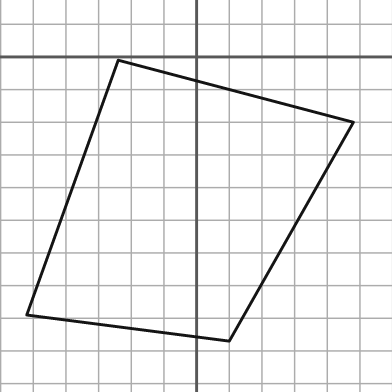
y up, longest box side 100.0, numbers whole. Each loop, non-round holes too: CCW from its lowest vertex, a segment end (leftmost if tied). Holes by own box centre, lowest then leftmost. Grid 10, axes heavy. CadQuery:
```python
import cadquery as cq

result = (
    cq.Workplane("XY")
    .moveTo(10.0, -87.0)
    .lineTo(48.0, -20.0)
    .lineTo(-24.0, -1.0)
    .lineTo(-52.0, -79.0)
    .close()
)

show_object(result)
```